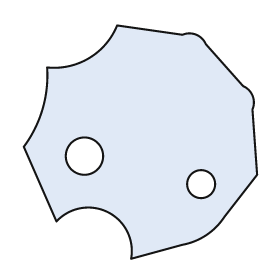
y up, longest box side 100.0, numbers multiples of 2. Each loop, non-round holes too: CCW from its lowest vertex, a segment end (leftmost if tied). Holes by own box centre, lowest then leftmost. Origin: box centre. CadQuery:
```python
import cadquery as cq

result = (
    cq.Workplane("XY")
    .moveTo(-4.0, -50.0)
    .lineTo(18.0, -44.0)
    .threePointArc((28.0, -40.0), (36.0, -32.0))
    .lineTo(50.0, -14.0)
    .lineTo(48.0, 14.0)
    .threePointArc((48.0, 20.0), (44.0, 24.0))
    .lineTo(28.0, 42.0)
    .threePointArc((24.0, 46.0), (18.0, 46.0))
    .lineTo(-10.0, 50.0)
    .threePointArc((-22.0, 36.0), (-40.0, 32.0))
    .threePointArc((-42.0, 14.0), (-50.0, -2.0))
    .lineTo(-36.0, -34.0)
    .threePointArc((-14.0, -30.0), (-4.0, -50.0))
    .close()
    .moveTo(26.0, -18.0)
    .circle(6.0)
    .moveTo(-24.0, -6.0)
    .circle(8.0)
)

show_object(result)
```